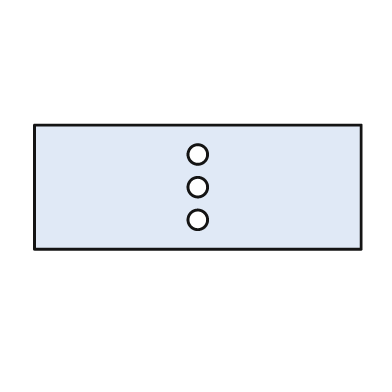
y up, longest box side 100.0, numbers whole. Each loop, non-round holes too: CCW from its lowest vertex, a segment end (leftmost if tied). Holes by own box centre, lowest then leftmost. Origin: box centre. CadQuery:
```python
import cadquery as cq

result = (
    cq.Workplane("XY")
    .moveTo(-50.0, -19.0)
    .lineTo(50.0, -19.0)
    .lineTo(50.0, 19.0)
    .lineTo(-50.0, 19.0)
    .close()
    .moveTo(0.0, -10.0)
    .circle(3.0)
    .moveTo(0.0, 0.0)
    .circle(3.0)
    .moveTo(0.0, 10.0)
    .circle(3.0)
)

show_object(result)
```